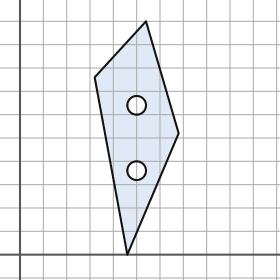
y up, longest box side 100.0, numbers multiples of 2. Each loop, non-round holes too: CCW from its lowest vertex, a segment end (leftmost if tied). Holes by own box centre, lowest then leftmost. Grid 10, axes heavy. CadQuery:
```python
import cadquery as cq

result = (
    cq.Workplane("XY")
    .moveTo(46.0, 0.0)
    .lineTo(68.0, 52.0)
    .lineTo(54.0, 100.0)
    .lineTo(32.0, 76.0)
    .close()
    .moveTo(50.0, 36.0)
    .circle(4.0)
    .moveTo(50.0, 64.0)
    .circle(4.0)
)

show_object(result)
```